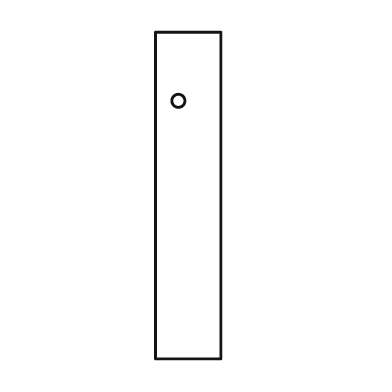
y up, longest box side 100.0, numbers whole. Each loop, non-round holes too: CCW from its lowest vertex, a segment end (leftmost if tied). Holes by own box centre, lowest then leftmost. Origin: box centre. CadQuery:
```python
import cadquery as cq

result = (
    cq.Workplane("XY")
    .moveTo(-10.0, -50.0)
    .lineTo(10.0, -50.0)
    .lineTo(10.0, 50.0)
    .lineTo(-10.0, 50.0)
    .close()
    .moveTo(-3.0, 29.0)
    .circle(2.0)
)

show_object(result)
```